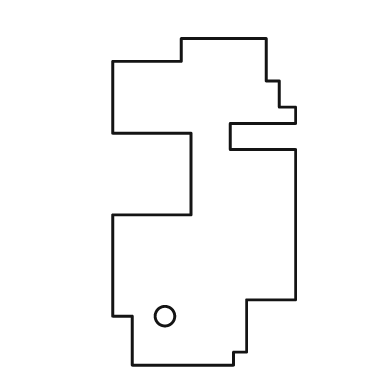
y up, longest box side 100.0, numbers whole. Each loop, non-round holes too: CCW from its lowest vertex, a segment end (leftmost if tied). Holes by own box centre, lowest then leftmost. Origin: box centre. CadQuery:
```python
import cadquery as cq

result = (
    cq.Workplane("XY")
    .moveTo(-22.0, -50.0)
    .lineTo(9.0, -50.0)
    .lineTo(9.0, -46.0)
    .lineTo(13.0, -46.0)
    .lineTo(13.0, -30.0)
    .lineTo(28.0, -30.0)
    .lineTo(28.0, 16.0)
    .lineTo(8.0, 16.0)
    .lineTo(8.0, 24.0)
    .lineTo(28.0, 24.0)
    .lineTo(28.0, 29.0)
    .lineTo(23.0, 29.0)
    .lineTo(23.0, 37.0)
    .lineTo(19.0, 37.0)
    .lineTo(19.0, 50.0)
    .lineTo(-7.0, 50.0)
    .lineTo(-7.0, 43.0)
    .lineTo(-28.0, 43.0)
    .lineTo(-28.0, 21.0)
    .lineTo(-4.0, 21.0)
    .lineTo(-4.0, -4.0)
    .lineTo(-28.0, -4.0)
    .lineTo(-28.0, -35.0)
    .lineTo(-22.0, -35.0)
    .close()
    .moveTo(-12.0, -35.0)
    .circle(3.0)
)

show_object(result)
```